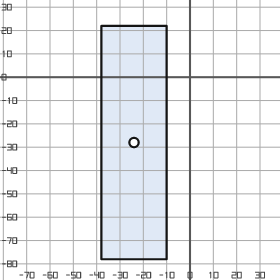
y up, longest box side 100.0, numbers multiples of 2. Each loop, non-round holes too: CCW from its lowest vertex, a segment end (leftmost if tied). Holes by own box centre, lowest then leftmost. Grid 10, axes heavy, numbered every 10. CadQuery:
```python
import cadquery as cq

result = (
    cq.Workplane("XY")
    .moveTo(-38.0, -78.0)
    .lineTo(-10.0, -78.0)
    .lineTo(-10.0, 22.0)
    .lineTo(-38.0, 22.0)
    .close()
    .moveTo(-24.0, -28.0)
    .circle(2.0)
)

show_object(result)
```